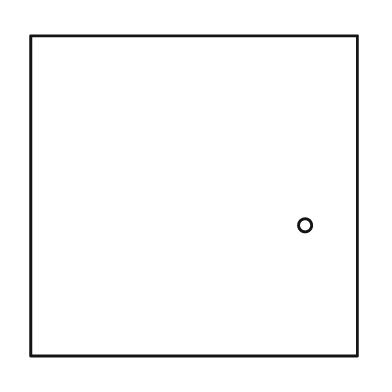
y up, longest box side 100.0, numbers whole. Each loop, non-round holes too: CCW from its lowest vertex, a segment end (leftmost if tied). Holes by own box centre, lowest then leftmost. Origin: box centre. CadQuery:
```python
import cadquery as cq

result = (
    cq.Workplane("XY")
    .moveTo(-50.0, -49.0)
    .lineTo(50.0, -49.0)
    .lineTo(50.0, 49.0)
    .lineTo(-50.0, 49.0)
    .close()
    .moveTo(34.0, -9.0)
    .circle(2.0)
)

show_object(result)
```